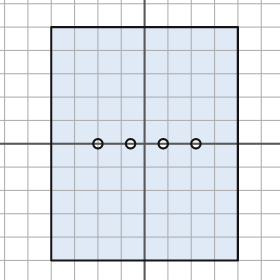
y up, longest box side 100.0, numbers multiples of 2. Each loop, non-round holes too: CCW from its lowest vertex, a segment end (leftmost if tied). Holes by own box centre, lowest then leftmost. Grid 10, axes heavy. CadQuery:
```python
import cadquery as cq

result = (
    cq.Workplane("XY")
    .moveTo(-40.0, -50.0)
    .lineTo(40.0, -50.0)
    .lineTo(40.0, 50.0)
    .lineTo(-40.0, 50.0)
    .close()
    .moveTo(-20.0, 0.0)
    .circle(2.0)
    .moveTo(-6.0, 0.0)
    .circle(2.0)
    .moveTo(8.0, 0.0)
    .circle(2.0)
    .moveTo(22.0, 0.0)
    .circle(2.0)
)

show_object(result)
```